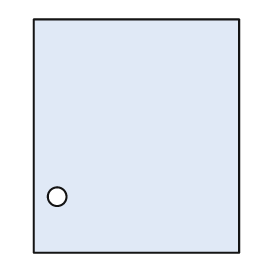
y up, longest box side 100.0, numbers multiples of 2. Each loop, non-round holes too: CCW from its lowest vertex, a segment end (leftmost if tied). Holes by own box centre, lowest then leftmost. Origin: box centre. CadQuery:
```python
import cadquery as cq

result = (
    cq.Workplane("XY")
    .moveTo(-44.0, -50.0)
    .lineTo(44.0, -50.0)
    .lineTo(44.0, 50.0)
    .lineTo(-44.0, 50.0)
    .close()
    .moveTo(-34.0, -26.0)
    .circle(4.0)
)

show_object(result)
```